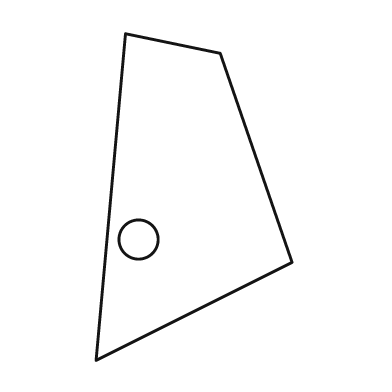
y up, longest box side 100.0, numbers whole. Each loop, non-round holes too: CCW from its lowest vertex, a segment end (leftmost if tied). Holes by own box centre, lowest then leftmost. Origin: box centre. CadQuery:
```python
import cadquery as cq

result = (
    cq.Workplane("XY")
    .moveTo(-30.0, -50.0)
    .lineTo(30.0, -20.0)
    .lineTo(8.0, 44.0)
    .lineTo(-21.0, 50.0)
    .close()
    .moveTo(-17.0, -13.0)
    .circle(6.0)
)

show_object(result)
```